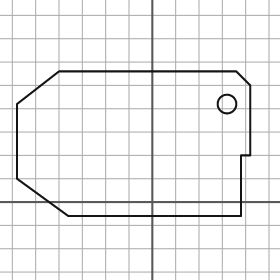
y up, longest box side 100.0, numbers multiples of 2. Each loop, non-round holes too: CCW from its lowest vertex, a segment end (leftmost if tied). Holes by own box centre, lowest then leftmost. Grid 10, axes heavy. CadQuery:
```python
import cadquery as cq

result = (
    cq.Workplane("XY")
    .moveTo(-36.0, -6.0)
    .lineTo(38.0, -6.0)
    .lineTo(38.0, 20.0)
    .lineTo(42.0, 20.0)
    .lineTo(42.0, 50.0)
    .lineTo(36.0, 56.0)
    .lineTo(-40.0, 56.0)
    .lineTo(-58.0, 42.0)
    .lineTo(-58.0, 10.0)
    .close()
    .moveTo(32.0, 42.0)
    .circle(4.0)
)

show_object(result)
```